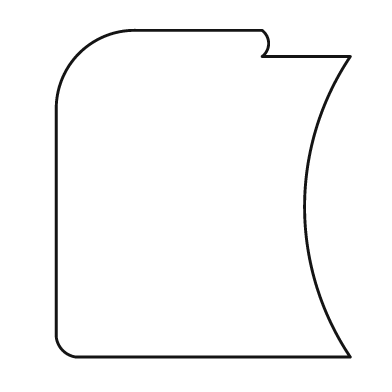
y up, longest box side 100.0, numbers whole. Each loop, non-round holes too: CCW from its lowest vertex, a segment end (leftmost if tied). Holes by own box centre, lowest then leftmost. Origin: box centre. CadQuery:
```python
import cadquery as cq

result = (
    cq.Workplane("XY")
    .moveTo(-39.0, -50.0)
    .lineTo(45.0, -50.0)
    .threePointArc((31.0, -4.0), (45.0, 42.0))
    .lineTo(18.0, 42.0)
    .threePointArc((20.0, 46.0), (18.0, 50.0))
    .lineTo(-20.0, 50.0)
    .threePointArc((-38.0, 43.0), (-45.0, 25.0))
    .lineTo(-45.0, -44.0)
    .threePointArc((-43.0, -48.0), (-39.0, -50.0))
    .close()
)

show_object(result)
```